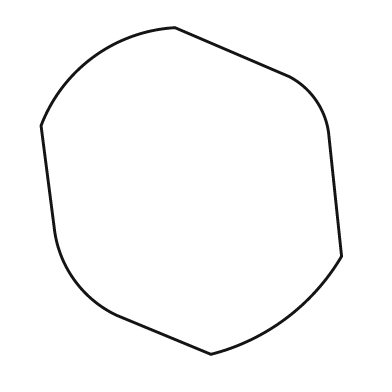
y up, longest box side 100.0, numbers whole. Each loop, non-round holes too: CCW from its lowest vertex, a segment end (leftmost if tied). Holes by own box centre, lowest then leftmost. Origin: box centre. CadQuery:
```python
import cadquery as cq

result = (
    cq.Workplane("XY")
    .moveTo(6.0, -50.0)
    .threePointArc((29.0, -39.0), (46.0, -20.0))
    .lineTo(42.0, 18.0)
    .threePointArc((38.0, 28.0), (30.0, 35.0))
    .lineTo(-5.0, 50.0)
    .threePointArc((-30.0, 41.0), (-46.0, 20.0))
    .lineTo(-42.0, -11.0)
    .threePointArc((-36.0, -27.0), (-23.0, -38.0))
    .close()
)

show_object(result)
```